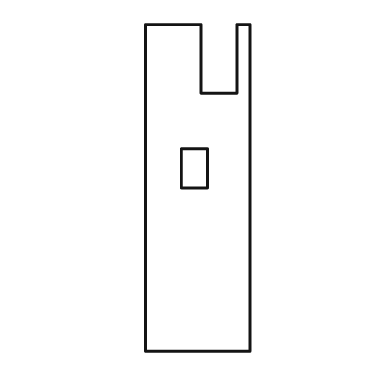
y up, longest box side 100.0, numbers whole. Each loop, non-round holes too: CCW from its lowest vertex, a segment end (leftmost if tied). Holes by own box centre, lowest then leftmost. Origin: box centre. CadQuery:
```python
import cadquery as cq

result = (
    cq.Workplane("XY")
    .moveTo(-16.0, -50.0)
    .lineTo(16.0, -50.0)
    .lineTo(16.0, 50.0)
    .lineTo(12.0, 50.0)
    .lineTo(12.0, 29.0)
    .lineTo(1.0, 29.0)
    .lineTo(1.0, 50.0)
    .lineTo(-16.0, 50.0)
    .close()
    .moveTo(-5.0, 0.0)
    .lineTo(3.0, 0.0)
    .lineTo(3.0, 12.0)
    .lineTo(-5.0, 12.0)
    .close()
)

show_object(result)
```